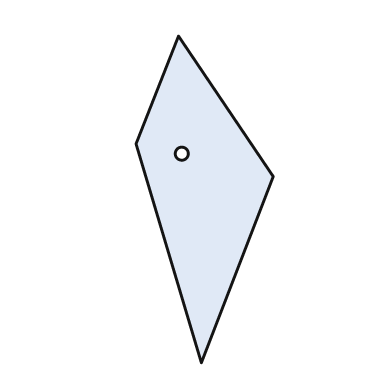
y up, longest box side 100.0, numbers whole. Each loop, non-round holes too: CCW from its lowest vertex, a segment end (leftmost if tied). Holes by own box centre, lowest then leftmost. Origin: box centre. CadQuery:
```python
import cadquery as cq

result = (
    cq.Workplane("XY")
    .moveTo(-1.0, -50.0)
    .lineTo(21.0, 7.0)
    .lineTo(-8.0, 50.0)
    .lineTo(-21.0, 17.0)
    .close()
    .moveTo(-7.0, 14.0)
    .circle(2.0)
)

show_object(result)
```